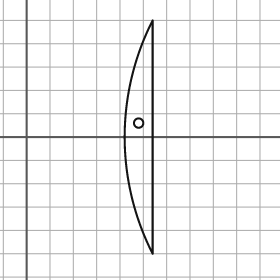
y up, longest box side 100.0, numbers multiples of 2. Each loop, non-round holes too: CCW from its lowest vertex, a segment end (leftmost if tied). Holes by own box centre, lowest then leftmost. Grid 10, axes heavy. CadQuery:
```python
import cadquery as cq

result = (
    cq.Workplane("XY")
    .moveTo(54.0, -50.0)
    .lineTo(54.0, 50.0)
    .threePointArc((42.0, 0.0), (54.0, -50.0))
    .close()
    .moveTo(48.0, 6.0)
    .circle(2.0)
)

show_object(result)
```